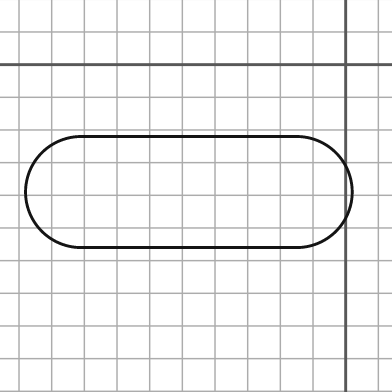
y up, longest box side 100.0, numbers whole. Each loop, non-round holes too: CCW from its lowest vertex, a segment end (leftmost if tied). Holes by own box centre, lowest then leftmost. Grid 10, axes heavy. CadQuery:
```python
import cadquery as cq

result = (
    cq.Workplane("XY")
    .moveTo(-81.0, -56.0)
    .lineTo(-15.0, -56.0)
    .threePointArc((2.0, -39.0), (-15.0, -22.0))
    .lineTo(-81.0, -22.0)
    .threePointArc((-98.0, -39.0), (-81.0, -56.0))
    .close()
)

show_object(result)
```